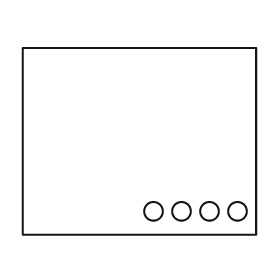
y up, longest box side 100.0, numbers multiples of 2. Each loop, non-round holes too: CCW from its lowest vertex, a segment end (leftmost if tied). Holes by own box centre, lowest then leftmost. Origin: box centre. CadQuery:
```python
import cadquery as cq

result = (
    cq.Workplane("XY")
    .moveTo(-50.0, -40.0)
    .lineTo(50.0, -40.0)
    .lineTo(50.0, 40.0)
    .lineTo(-50.0, 40.0)
    .close()
    .moveTo(6.0, -30.0)
    .circle(4.0)
    .moveTo(18.0, -30.0)
    .circle(4.0)
    .moveTo(30.0, -30.0)
    .circle(4.0)
    .moveTo(42.0, -30.0)
    .circle(4.0)
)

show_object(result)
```